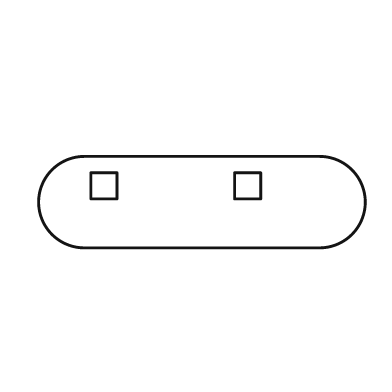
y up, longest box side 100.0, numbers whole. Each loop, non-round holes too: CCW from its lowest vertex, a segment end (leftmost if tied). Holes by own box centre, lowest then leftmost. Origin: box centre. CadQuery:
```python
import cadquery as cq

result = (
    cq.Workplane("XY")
    .moveTo(-36.0, -14.0)
    .lineTo(36.0, -14.0)
    .threePointArc((50.0, 0.0), (36.0, 14.0))
    .lineTo(-36.0, 14.0)
    .threePointArc((-50.0, 0.0), (-36.0, -14.0))
    .close()
    .moveTo(-34.0, 1.0)
    .lineTo(-26.0, 1.0)
    .lineTo(-26.0, 9.0)
    .lineTo(-34.0, 9.0)
    .close()
    .moveTo(10.0, 1.0)
    .lineTo(18.0, 1.0)
    .lineTo(18.0, 9.0)
    .lineTo(10.0, 9.0)
    .close()
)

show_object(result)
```